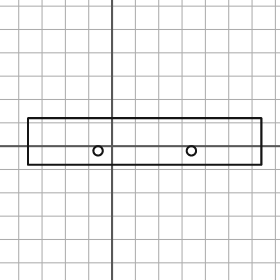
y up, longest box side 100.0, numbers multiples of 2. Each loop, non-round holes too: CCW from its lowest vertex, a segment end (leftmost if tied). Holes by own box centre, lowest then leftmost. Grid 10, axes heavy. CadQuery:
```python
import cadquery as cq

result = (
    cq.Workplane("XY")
    .moveTo(-36.0, -8.0)
    .lineTo(64.0, -8.0)
    .lineTo(64.0, 12.0)
    .lineTo(-36.0, 12.0)
    .close()
    .moveTo(-6.0, -2.0)
    .circle(2.0)
    .moveTo(34.0, -2.0)
    .circle(2.0)
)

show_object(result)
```